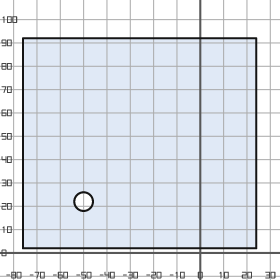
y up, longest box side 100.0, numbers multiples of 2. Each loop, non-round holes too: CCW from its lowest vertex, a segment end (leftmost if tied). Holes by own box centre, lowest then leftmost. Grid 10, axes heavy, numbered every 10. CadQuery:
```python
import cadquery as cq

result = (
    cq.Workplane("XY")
    .moveTo(-76.0, 2.0)
    .lineTo(24.0, 2.0)
    .lineTo(24.0, 92.0)
    .lineTo(-76.0, 92.0)
    .close()
    .moveTo(-50.0, 22.0)
    .circle(4.0)
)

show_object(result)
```